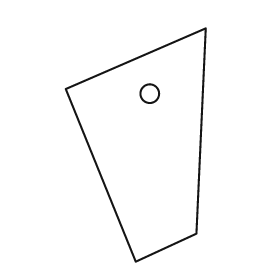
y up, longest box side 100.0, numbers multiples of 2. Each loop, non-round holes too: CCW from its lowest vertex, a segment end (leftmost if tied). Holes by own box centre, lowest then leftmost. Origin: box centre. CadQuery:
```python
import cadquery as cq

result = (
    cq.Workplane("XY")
    .moveTo(0.0, -50.0)
    .lineTo(26.0, -38.0)
    .lineTo(30.0, 50.0)
    .lineTo(-30.0, 24.0)
    .close()
    .moveTo(6.0, 22.0)
    .circle(4.0)
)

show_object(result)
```